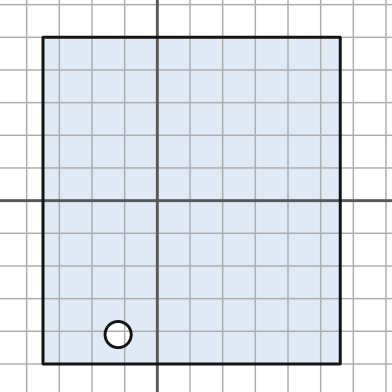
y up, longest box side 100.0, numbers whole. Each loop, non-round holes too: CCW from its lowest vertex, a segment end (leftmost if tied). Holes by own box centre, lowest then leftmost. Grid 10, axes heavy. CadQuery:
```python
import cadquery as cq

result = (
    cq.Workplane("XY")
    .moveTo(-35.0, -50.0)
    .lineTo(56.0, -50.0)
    .lineTo(56.0, 50.0)
    .lineTo(-35.0, 50.0)
    .close()
    .moveTo(-12.0, -41.0)
    .circle(4.0)
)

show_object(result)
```